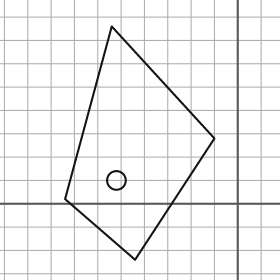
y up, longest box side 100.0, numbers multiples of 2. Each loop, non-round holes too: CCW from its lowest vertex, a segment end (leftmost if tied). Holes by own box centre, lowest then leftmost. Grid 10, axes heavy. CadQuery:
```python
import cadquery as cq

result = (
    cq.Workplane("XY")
    .moveTo(-44.0, -24.0)
    .lineTo(-10.0, 28.0)
    .lineTo(-54.0, 76.0)
    .lineTo(-74.0, 2.0)
    .close()
    .moveTo(-52.0, 10.0)
    .circle(4.0)
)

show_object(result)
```